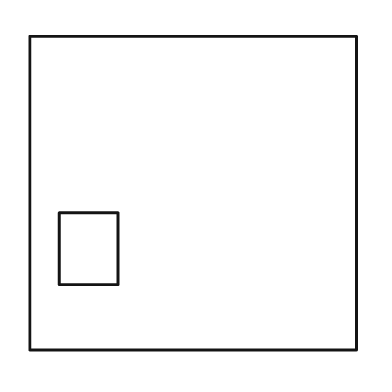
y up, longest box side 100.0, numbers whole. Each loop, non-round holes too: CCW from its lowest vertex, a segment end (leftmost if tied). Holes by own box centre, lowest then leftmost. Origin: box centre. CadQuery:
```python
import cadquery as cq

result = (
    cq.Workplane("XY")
    .moveTo(-50.0, -48.0)
    .lineTo(50.0, -48.0)
    .lineTo(50.0, 48.0)
    .lineTo(-50.0, 48.0)
    .close()
    .moveTo(-41.0, -28.0)
    .lineTo(-23.0, -28.0)
    .lineTo(-23.0, -6.0)
    .lineTo(-41.0, -6.0)
    .close()
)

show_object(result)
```